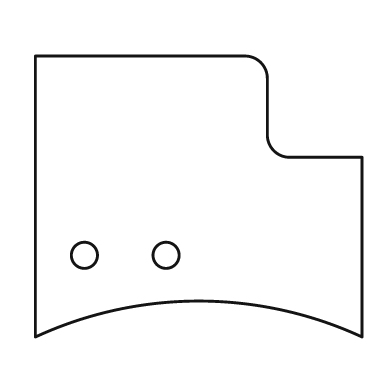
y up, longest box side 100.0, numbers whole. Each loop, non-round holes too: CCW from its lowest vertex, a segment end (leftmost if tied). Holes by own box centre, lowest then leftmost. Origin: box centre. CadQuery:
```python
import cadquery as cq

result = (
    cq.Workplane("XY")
    .moveTo(-50.0, -43.0)
    .threePointArc((0.0, -32.0), (50.0, -43.0))
    .lineTo(50.0, 12.0)
    .lineTo(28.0, 12.0)
    .threePointArc((23.0, 14.0), (21.0, 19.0))
    .lineTo(21.0, 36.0)
    .threePointArc((19.0, 41.0), (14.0, 43.0))
    .lineTo(-50.0, 43.0)
    .close()
    .moveTo(-35.0, -18.0)
    .circle(4.0)
    .moveTo(-10.0, -18.0)
    .circle(4.0)
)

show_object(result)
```